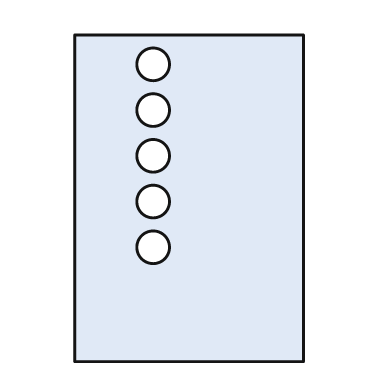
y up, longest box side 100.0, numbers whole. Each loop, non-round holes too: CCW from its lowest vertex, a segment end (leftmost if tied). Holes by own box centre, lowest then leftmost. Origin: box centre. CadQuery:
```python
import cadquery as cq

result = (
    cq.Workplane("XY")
    .moveTo(-35.0, -50.0)
    .lineTo(35.0, -50.0)
    .lineTo(35.0, 50.0)
    .lineTo(-35.0, 50.0)
    .close()
    .moveTo(-11.0, -15.0)
    .circle(5.0)
    .moveTo(-11.0, -1.0)
    .circle(5.0)
    .moveTo(-11.0, 13.0)
    .circle(5.0)
    .moveTo(-11.0, 27.0)
    .circle(5.0)
    .moveTo(-11.0, 41.0)
    .circle(5.0)
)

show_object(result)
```